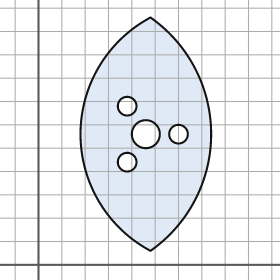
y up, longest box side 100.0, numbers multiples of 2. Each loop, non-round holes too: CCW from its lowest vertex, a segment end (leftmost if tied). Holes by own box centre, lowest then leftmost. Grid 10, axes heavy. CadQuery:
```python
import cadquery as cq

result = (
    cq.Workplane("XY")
    .moveTo(48.0, 6.0)
    .threePointArc((74.0, 56.0), (48.0, 106.0))
    .threePointArc((18.0, 56.0), (48.0, 6.0))
    .close()
    .moveTo(38.0, 44.0)
    .circle(4.0)
    .moveTo(46.0, 56.0)
    .circle(6.0)
    .moveTo(60.0, 56.0)
    .circle(4.0)
    .moveTo(38.0, 68.0)
    .circle(4.0)
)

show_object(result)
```